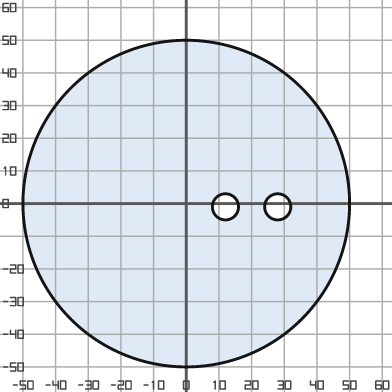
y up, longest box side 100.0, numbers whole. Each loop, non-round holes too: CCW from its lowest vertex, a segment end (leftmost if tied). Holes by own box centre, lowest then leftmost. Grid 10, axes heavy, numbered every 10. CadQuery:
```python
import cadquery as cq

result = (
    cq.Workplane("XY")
    .moveTo(0.0, 0.0)
    .circle(50.0)
    .moveTo(12.0, -1.0)
    .circle(4.0)
    .moveTo(28.0, -1.0)
    .circle(4.0)
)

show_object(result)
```